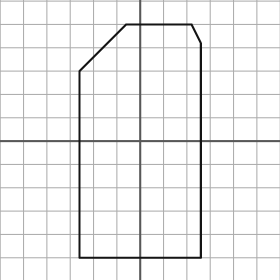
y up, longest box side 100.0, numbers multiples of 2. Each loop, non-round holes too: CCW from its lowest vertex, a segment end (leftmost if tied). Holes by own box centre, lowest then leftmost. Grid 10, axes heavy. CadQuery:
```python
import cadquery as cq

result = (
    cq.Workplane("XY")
    .moveTo(-26.0, -50.0)
    .lineTo(26.0, -50.0)
    .lineTo(26.0, 42.0)
    .lineTo(22.0, 50.0)
    .lineTo(-6.0, 50.0)
    .lineTo(-26.0, 30.0)
    .close()
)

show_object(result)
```